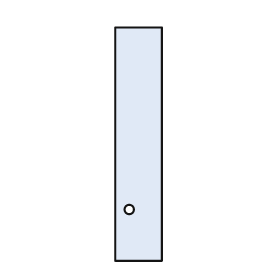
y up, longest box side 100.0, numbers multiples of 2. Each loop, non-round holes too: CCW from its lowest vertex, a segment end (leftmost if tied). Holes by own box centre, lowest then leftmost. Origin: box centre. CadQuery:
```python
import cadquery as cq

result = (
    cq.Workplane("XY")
    .moveTo(-10.0, -50.0)
    .lineTo(10.0, -50.0)
    .lineTo(10.0, 50.0)
    .lineTo(-10.0, 50.0)
    .close()
    .moveTo(-4.0, -28.0)
    .circle(2.0)
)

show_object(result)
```